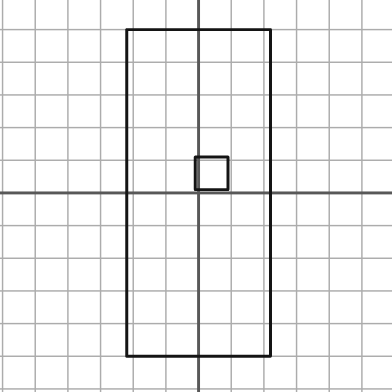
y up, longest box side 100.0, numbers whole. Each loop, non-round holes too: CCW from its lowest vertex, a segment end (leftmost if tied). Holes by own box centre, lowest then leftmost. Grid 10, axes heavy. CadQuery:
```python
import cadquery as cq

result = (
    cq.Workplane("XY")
    .moveTo(-22.0, -50.0)
    .lineTo(22.0, -50.0)
    .lineTo(22.0, 50.0)
    .lineTo(-22.0, 50.0)
    .close()
    .moveTo(-1.0, 1.0)
    .lineTo(9.0, 1.0)
    .lineTo(9.0, 11.0)
    .lineTo(-1.0, 11.0)
    .close()
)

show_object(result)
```